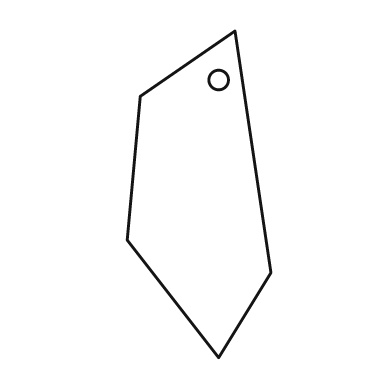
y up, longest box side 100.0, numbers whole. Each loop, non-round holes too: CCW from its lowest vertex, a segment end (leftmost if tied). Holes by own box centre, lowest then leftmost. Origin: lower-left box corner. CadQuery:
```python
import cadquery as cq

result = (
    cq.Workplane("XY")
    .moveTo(28.0, 0.0)
    .lineTo(44.0, 26.0)
    .lineTo(33.0, 100.0)
    .lineTo(4.0, 80.0)
    .lineTo(0.0, 36.0)
    .close()
    .moveTo(28.0, 85.0)
    .circle(3.0)
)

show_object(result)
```